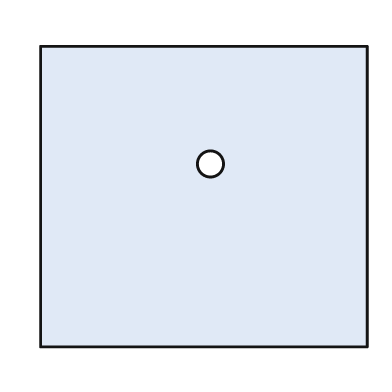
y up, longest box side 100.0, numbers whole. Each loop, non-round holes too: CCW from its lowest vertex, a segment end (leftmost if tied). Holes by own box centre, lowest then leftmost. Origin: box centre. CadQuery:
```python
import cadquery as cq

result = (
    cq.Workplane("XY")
    .moveTo(-50.0, -46.0)
    .lineTo(50.0, -46.0)
    .lineTo(50.0, 46.0)
    .lineTo(-50.0, 46.0)
    .close()
    .moveTo(2.0, 10.0)
    .circle(4.0)
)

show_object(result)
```